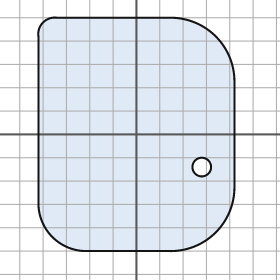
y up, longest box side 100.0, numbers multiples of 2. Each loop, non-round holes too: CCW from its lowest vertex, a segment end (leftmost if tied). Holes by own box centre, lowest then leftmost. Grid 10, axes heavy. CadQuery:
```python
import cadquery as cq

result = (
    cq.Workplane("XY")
    .moveTo(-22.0, -50.0)
    .lineTo(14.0, -50.0)
    .threePointArc((34.0, -42.0), (42.0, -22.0))
    .lineTo(42.0, 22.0)
    .threePointArc((34.0, 42.0), (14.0, 50.0))
    .lineTo(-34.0, 50.0)
    .threePointArc((-40.0, 48.0), (-42.0, 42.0))
    .lineTo(-42.0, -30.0)
    .threePointArc((-36.0, -44.0), (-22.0, -50.0))
    .close()
    .moveTo(28.0, -14.0)
    .circle(4.0)
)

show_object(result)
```